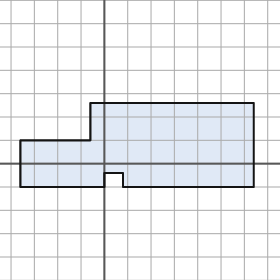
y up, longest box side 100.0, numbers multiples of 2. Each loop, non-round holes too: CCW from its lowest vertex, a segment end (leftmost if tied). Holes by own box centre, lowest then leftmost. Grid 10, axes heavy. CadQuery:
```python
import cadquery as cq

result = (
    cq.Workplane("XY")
    .moveTo(-36.0, -10.0)
    .lineTo(0.0, -10.0)
    .lineTo(0.0, -4.0)
    .lineTo(8.0, -4.0)
    .lineTo(8.0, -10.0)
    .lineTo(64.0, -10.0)
    .lineTo(64.0, 26.0)
    .lineTo(-6.0, 26.0)
    .lineTo(-6.0, 10.0)
    .lineTo(-36.0, 10.0)
    .close()
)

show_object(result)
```